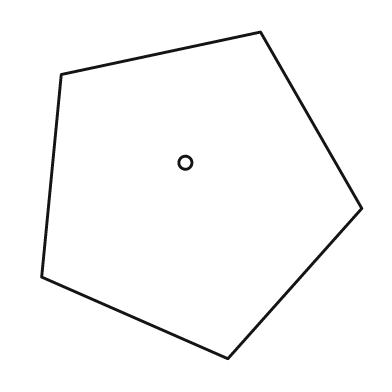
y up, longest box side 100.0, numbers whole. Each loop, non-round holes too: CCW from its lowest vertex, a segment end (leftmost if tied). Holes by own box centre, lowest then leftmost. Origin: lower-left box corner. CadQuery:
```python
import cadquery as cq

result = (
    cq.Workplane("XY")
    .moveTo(57.0, 0.0)
    .lineTo(98.0, 46.0)
    .lineTo(67.0, 100.0)
    .lineTo(6.0, 87.0)
    .lineTo(0.0, 25.0)
    .close()
    .moveTo(44.0, 60.0)
    .circle(2.0)
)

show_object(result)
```